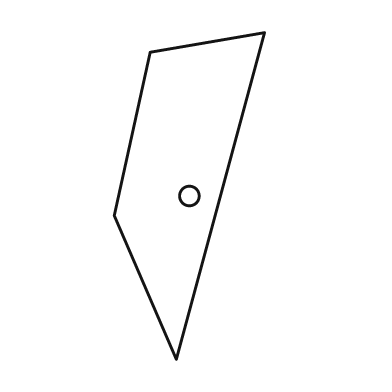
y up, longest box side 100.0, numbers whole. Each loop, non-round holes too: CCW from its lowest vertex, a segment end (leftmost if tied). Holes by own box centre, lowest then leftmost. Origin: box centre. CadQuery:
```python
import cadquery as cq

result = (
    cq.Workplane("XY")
    .moveTo(-4.0, -50.0)
    .lineTo(23.0, 50.0)
    .lineTo(-12.0, 44.0)
    .lineTo(-23.0, -6.0)
    .close()
    .moveTo(0.0, 0.0)
    .circle(3.0)
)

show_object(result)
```